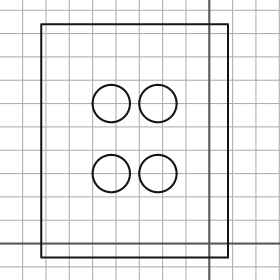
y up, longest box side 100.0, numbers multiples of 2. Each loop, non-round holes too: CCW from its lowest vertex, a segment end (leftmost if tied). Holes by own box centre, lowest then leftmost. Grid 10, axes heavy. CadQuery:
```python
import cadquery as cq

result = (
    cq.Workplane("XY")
    .moveTo(-72.0, -6.0)
    .lineTo(8.0, -6.0)
    .lineTo(8.0, 94.0)
    .lineTo(-72.0, 94.0)
    .close()
    .moveTo(-42.0, 30.0)
    .circle(8.0)
    .moveTo(-22.0, 30.0)
    .circle(8.0)
    .moveTo(-42.0, 60.0)
    .circle(8.0)
    .moveTo(-22.0, 60.0)
    .circle(8.0)
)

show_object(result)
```